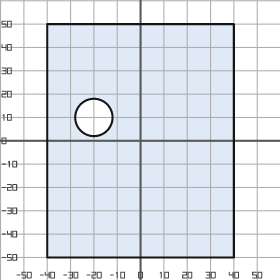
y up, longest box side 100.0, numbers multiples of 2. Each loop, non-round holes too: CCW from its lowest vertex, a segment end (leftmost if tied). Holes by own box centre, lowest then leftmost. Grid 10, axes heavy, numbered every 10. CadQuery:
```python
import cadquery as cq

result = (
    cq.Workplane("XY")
    .moveTo(-40.0, -50.0)
    .lineTo(40.0, -50.0)
    .lineTo(40.0, 50.0)
    .lineTo(-40.0, 50.0)
    .close()
    .moveTo(-20.0, 10.0)
    .circle(8.0)
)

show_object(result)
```